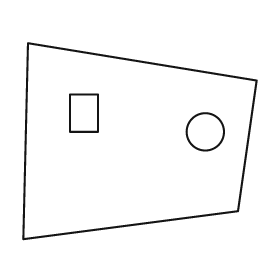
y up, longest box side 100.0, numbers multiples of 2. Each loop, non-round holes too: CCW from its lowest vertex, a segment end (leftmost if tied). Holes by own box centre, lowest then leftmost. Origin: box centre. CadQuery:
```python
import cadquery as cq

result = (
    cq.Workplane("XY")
    .moveTo(-50.0, -42.0)
    .lineTo(42.0, -30.0)
    .lineTo(50.0, 26.0)
    .lineTo(-48.0, 42.0)
    .close()
    .moveTo(28.0, 4.0)
    .circle(8.0)
    .moveTo(-30.0, 4.0)
    .lineTo(-18.0, 4.0)
    .lineTo(-18.0, 20.0)
    .lineTo(-30.0, 20.0)
    .close()
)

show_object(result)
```